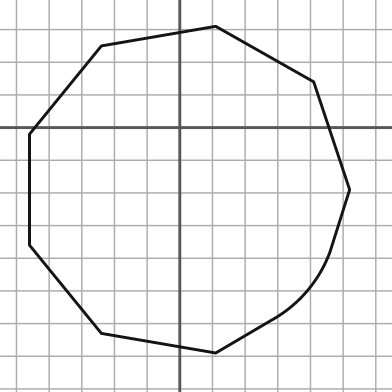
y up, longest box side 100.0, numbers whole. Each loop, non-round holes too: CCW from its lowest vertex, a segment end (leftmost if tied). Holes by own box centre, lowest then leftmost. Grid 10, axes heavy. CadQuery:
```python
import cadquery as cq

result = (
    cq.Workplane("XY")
    .moveTo(11.0, -69.0)
    .lineTo(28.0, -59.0)
    .threePointArc((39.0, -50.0), (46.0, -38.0))
    .lineTo(52.0, -19.0)
    .lineTo(41.0, 14.0)
    .lineTo(11.0, 31.0)
    .lineTo(-24.0, 25.0)
    .lineTo(-46.0, -2.0)
    .lineTo(-46.0, -36.0)
    .lineTo(-24.0, -63.0)
    .close()
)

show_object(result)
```